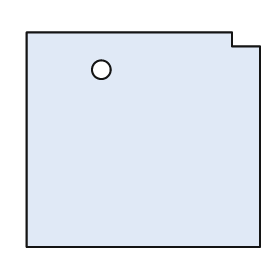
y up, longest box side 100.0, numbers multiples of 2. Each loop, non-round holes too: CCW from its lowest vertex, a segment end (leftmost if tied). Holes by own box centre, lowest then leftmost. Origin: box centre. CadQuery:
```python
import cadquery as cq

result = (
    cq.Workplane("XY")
    .moveTo(-50.0, -46.0)
    .lineTo(50.0, -46.0)
    .lineTo(50.0, 40.0)
    .lineTo(38.0, 40.0)
    .lineTo(38.0, 46.0)
    .lineTo(-50.0, 46.0)
    .close()
    .moveTo(-18.0, 30.0)
    .circle(4.0)
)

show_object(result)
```